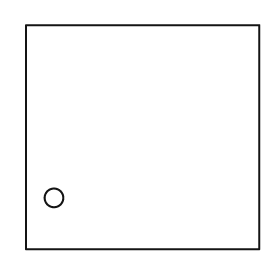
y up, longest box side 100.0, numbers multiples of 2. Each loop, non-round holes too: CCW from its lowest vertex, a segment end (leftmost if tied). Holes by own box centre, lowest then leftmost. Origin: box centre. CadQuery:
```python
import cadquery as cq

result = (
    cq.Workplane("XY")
    .moveTo(-50.0, -48.0)
    .lineTo(50.0, -48.0)
    .lineTo(50.0, 48.0)
    .lineTo(-50.0, 48.0)
    .close()
    .moveTo(-38.0, -26.0)
    .circle(4.0)
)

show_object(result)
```